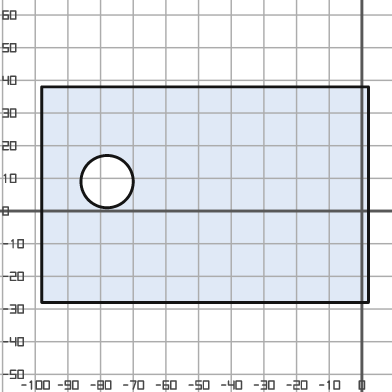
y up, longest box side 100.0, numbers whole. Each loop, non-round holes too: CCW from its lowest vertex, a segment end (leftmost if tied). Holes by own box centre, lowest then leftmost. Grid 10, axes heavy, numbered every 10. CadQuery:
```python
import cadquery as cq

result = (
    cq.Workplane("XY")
    .moveTo(-98.0, -28.0)
    .lineTo(2.0, -28.0)
    .lineTo(2.0, 38.0)
    .lineTo(-98.0, 38.0)
    .close()
    .moveTo(-78.0, 9.0)
    .circle(8.0)
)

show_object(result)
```